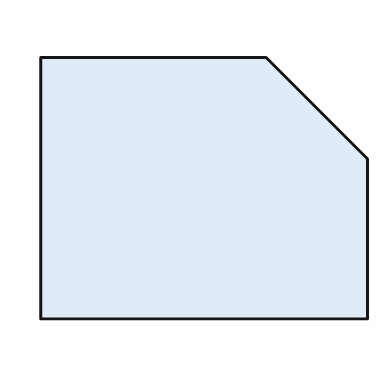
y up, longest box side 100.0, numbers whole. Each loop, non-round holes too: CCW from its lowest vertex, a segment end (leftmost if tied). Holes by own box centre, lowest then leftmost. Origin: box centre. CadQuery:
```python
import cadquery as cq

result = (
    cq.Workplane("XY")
    .moveTo(-50.0, -40.0)
    .lineTo(50.0, -40.0)
    .lineTo(50.0, 9.0)
    .lineTo(19.0, 40.0)
    .lineTo(-50.0, 40.0)
    .close()
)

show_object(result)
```